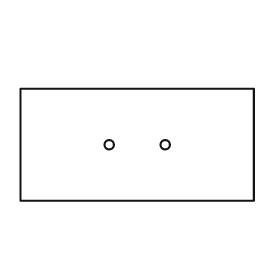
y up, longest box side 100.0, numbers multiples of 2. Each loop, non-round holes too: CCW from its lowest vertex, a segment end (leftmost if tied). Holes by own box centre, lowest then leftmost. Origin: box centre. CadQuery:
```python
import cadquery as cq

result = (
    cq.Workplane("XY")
    .moveTo(-50.0, -24.0)
    .lineTo(50.0, -24.0)
    .lineTo(50.0, 24.0)
    .lineTo(-50.0, 24.0)
    .close()
    .moveTo(-12.0, 0.0)
    .circle(2.0)
    .moveTo(12.0, 0.0)
    .circle(2.0)
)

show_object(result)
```